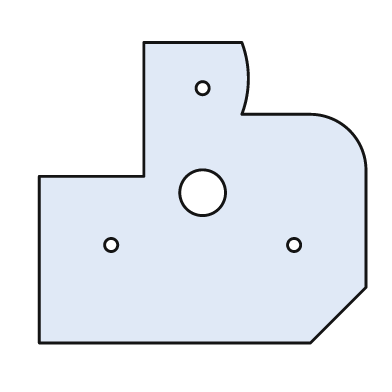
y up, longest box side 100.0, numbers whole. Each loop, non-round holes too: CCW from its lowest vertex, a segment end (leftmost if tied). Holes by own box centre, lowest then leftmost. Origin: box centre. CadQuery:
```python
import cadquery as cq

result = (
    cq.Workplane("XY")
    .moveTo(-50.0, -46.0)
    .lineTo(33.0, -46.0)
    .lineTo(50.0, -29.0)
    .lineTo(50.0, 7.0)
    .threePointArc((45.0, 19.0), (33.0, 24.0))
    .lineTo(12.0, 24.0)
    .threePointArc((14.0, 35.0), (12.0, 46.0))
    .lineTo(-18.0, 46.0)
    .lineTo(-18.0, 5.0)
    .lineTo(-50.0, 5.0)
    .close()
    .moveTo(-28.0, -16.0)
    .circle(2.0)
    .moveTo(28.0, -16.0)
    .circle(2.0)
    .moveTo(0.0, 0.0)
    .circle(7.0)
    .moveTo(0.0, 32.0)
    .circle(2.0)
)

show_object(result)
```